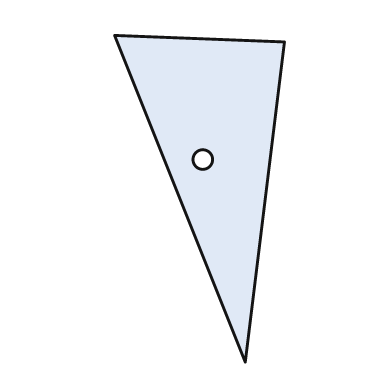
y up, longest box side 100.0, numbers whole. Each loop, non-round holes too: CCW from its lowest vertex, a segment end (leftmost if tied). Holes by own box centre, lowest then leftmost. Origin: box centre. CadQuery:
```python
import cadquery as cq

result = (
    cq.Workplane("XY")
    .moveTo(14.0, -50.0)
    .lineTo(26.0, 48.0)
    .lineTo(-26.0, 50.0)
    .close()
    .moveTo(1.0, 12.0)
    .circle(3.0)
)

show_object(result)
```